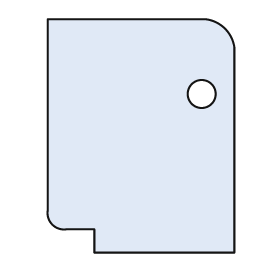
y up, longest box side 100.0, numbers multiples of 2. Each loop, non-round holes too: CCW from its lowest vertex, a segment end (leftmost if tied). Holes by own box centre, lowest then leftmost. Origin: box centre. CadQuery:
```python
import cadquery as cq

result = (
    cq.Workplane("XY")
    .moveTo(-20.0, -50.0)
    .lineTo(40.0, -50.0)
    .lineTo(40.0, 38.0)
    .threePointArc((36.0, 46.0), (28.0, 50.0))
    .lineTo(-40.0, 50.0)
    .lineTo(-40.0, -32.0)
    .threePointArc((-38.0, -38.0), (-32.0, -40.0))
    .lineTo(-20.0, -40.0)
    .close()
    .moveTo(26.0, 18.0)
    .circle(6.0)
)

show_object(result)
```